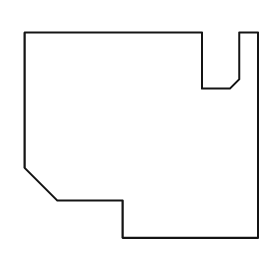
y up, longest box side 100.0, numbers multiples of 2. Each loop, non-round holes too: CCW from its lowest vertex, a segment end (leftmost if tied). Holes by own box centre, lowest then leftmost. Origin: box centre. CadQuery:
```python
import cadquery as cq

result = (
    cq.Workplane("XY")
    .moveTo(-8.0, -44.0)
    .lineTo(50.0, -44.0)
    .lineTo(50.0, 44.0)
    .lineTo(42.0, 44.0)
    .lineTo(42.0, 24.0)
    .lineTo(38.0, 20.0)
    .lineTo(26.0, 20.0)
    .lineTo(26.0, 44.0)
    .lineTo(-50.0, 44.0)
    .lineTo(-50.0, -14.0)
    .lineTo(-36.0, -28.0)
    .lineTo(-8.0, -28.0)
    .close()
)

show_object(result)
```